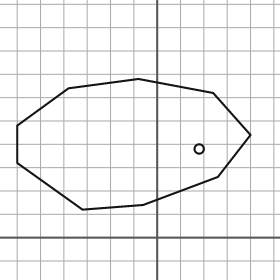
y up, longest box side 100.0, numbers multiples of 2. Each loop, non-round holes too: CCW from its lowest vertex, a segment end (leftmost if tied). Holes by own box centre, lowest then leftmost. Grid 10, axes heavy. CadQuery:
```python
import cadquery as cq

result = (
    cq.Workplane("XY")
    .moveTo(-32.0, 12.0)
    .lineTo(-6.0, 14.0)
    .lineTo(26.0, 26.0)
    .lineTo(40.0, 44.0)
    .lineTo(24.0, 62.0)
    .lineTo(-8.0, 68.0)
    .lineTo(-38.0, 64.0)
    .lineTo(-60.0, 48.0)
    .lineTo(-60.0, 32.0)
    .close()
    .moveTo(18.0, 38.0)
    .circle(2.0)
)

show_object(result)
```